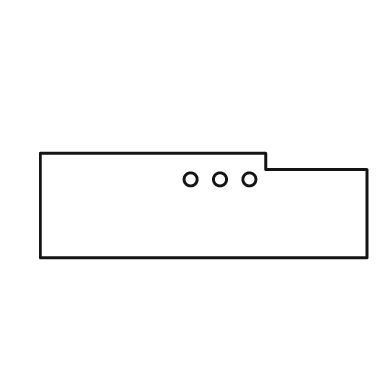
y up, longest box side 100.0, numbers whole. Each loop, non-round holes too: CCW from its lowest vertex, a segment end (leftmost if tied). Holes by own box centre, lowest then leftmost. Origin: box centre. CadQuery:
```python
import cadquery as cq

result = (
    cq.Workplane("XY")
    .moveTo(-50.0, -16.0)
    .lineTo(50.0, -16.0)
    .lineTo(50.0, 11.0)
    .lineTo(19.0, 11.0)
    .lineTo(19.0, 16.0)
    .lineTo(-50.0, 16.0)
    .close()
    .moveTo(-4.0, 8.0)
    .circle(2.0)
    .moveTo(5.0, 8.0)
    .circle(2.0)
    .moveTo(14.0, 8.0)
    .circle(2.0)
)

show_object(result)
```